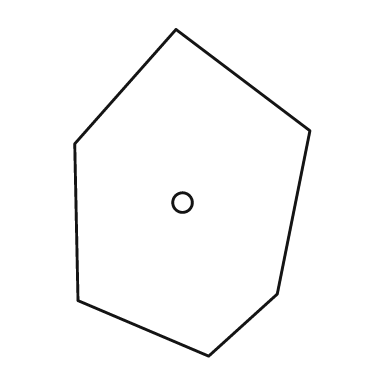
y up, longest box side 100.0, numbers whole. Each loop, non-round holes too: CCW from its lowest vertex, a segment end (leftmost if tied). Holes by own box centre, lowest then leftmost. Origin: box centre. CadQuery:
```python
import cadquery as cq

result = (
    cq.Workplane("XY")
    .moveTo(5.0, -50.0)
    .lineTo(26.0, -31.0)
    .lineTo(36.0, 19.0)
    .lineTo(-5.0, 50.0)
    .lineTo(-36.0, 15.0)
    .lineTo(-35.0, -33.0)
    .close()
    .moveTo(-3.0, -3.0)
    .circle(3.0)
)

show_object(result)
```